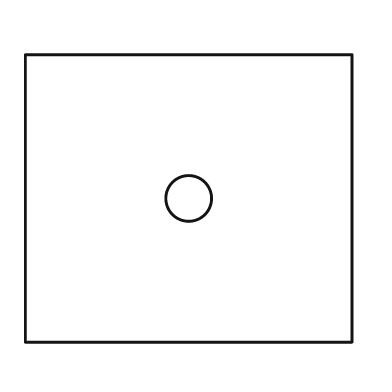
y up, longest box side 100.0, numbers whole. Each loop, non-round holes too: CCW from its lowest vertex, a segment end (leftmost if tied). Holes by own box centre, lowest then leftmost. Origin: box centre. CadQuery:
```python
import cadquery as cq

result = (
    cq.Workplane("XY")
    .moveTo(-50.0, -44.0)
    .lineTo(50.0, -44.0)
    .lineTo(50.0, 44.0)
    .lineTo(-50.0, 44.0)
    .close()
    .moveTo(0.0, 0.0)
    .circle(7.0)
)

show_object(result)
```